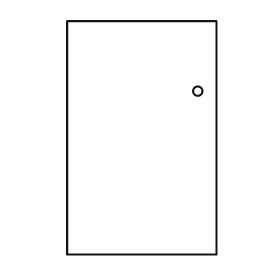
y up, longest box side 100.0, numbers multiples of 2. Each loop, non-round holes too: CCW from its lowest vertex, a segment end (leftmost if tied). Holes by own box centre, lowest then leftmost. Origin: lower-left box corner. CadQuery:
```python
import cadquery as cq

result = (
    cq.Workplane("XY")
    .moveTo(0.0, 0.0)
    .lineTo(64.0, 0.0)
    .lineTo(64.0, 100.0)
    .lineTo(0.0, 100.0)
    .close()
    .moveTo(56.0, 70.0)
    .circle(2.0)
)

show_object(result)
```